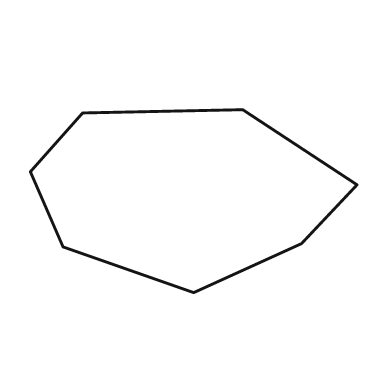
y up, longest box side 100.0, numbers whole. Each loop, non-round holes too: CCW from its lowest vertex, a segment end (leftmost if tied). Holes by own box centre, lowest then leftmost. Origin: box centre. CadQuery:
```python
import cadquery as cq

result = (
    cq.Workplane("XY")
    .moveTo(0.0, -28.0)
    .lineTo(33.0, -13.0)
    .lineTo(50.0, 5.0)
    .lineTo(15.0, 28.0)
    .lineTo(-34.0, 27.0)
    .lineTo(-50.0, 9.0)
    .lineTo(-40.0, -14.0)
    .close()
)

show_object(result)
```